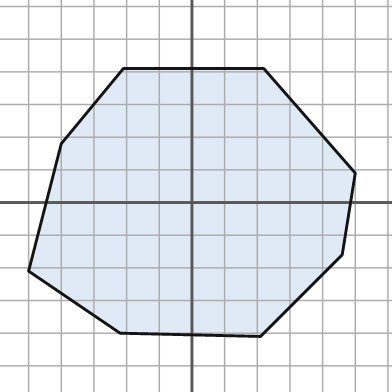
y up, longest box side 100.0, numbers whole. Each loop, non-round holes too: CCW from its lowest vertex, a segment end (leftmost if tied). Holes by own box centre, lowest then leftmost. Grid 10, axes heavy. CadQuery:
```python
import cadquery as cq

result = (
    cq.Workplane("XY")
    .moveTo(21.0, -41.0)
    .lineTo(46.0, -16.0)
    .lineTo(50.0, 9.0)
    .lineTo(22.0, 41.0)
    .lineTo(-21.0, 41.0)
    .lineTo(-40.0, 18.0)
    .lineTo(-50.0, -21.0)
    .lineTo(-22.0, -40.0)
    .close()
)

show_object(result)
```